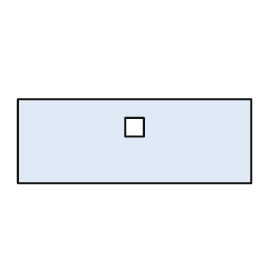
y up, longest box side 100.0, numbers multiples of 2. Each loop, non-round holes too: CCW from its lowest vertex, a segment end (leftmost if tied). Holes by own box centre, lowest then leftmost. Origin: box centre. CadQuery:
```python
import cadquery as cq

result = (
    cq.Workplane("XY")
    .moveTo(-50.0, -18.0)
    .lineTo(50.0, -18.0)
    .lineTo(50.0, 18.0)
    .lineTo(-50.0, 18.0)
    .close()
    .moveTo(-4.0, 2.0)
    .lineTo(4.0, 2.0)
    .lineTo(4.0, 10.0)
    .lineTo(-4.0, 10.0)
    .close()
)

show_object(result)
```